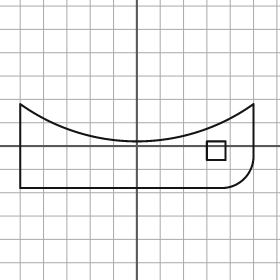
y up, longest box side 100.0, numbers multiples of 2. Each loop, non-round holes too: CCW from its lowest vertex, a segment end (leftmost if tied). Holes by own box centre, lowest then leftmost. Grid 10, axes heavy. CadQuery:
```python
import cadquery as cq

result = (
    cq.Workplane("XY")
    .moveTo(-50.0, -18.0)
    .lineTo(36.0, -18.0)
    .threePointArc((46.0, -14.0), (50.0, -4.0))
    .lineTo(50.0, 18.0)
    .threePointArc((0.0, 2.0), (-50.0, 18.0))
    .close()
    .moveTo(30.0, -6.0)
    .lineTo(38.0, -6.0)
    .lineTo(38.0, 2.0)
    .lineTo(30.0, 2.0)
    .close()
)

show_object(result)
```